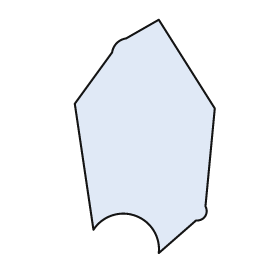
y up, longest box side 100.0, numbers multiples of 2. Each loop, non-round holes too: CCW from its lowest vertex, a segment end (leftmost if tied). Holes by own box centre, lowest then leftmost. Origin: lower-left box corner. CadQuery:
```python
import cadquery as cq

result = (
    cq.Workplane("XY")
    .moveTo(36.0, 0.0)
    .lineTo(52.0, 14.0)
    .threePointArc((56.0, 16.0), (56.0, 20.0))
    .lineTo(60.0, 62.0)
    .lineTo(36.0, 100.0)
    .lineTo(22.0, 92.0)
    .threePointArc((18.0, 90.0), (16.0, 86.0))
    .lineTo(0.0, 64.0)
    .lineTo(8.0, 10.0)
    .threePointArc((26.0, 16.0), (36.0, 0.0))
    .close()
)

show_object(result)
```